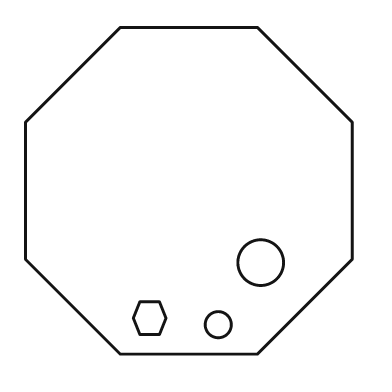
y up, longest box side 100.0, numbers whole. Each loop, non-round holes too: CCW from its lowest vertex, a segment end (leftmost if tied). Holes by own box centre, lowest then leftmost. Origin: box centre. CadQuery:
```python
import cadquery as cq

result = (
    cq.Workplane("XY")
    .moveTo(-21.0, -50.0)
    .lineTo(21.0, -50.0)
    .lineTo(50.0, -21.0)
    .lineTo(50.0, 21.0)
    .lineTo(21.0, 50.0)
    .lineTo(-21.0, 50.0)
    .lineTo(-50.0, 21.0)
    .lineTo(-50.0, -21.0)
    .close()
    .moveTo(9.0, -41.0)
    .circle(4.0)
    .moveTo(-15.0, -44.0)
    .lineTo(-9.0, -44.0)
    .lineTo(-7.0, -39.0)
    .lineTo(-9.0, -34.0)
    .lineTo(-15.0, -34.0)
    .lineTo(-17.0, -39.0)
    .close()
    .moveTo(22.0, -22.0)
    .circle(7.0)
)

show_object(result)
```